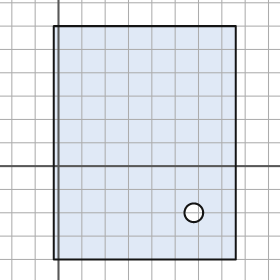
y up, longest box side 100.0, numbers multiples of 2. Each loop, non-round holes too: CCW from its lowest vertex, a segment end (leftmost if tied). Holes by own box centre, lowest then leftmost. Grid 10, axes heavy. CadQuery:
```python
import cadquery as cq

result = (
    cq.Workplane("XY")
    .moveTo(-2.0, -40.0)
    .lineTo(76.0, -40.0)
    .lineTo(76.0, 60.0)
    .lineTo(-2.0, 60.0)
    .close()
    .moveTo(58.0, -20.0)
    .circle(4.0)
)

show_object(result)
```